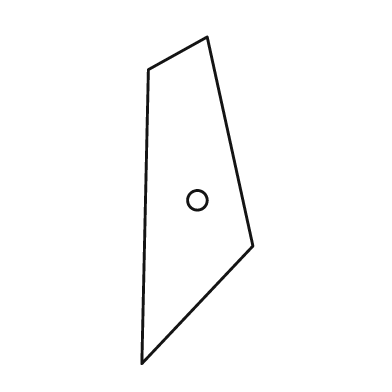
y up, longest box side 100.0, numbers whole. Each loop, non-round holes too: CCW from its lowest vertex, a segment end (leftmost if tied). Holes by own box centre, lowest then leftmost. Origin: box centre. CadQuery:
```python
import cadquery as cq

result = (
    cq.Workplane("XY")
    .moveTo(-17.0, -50.0)
    .lineTo(17.0, -14.0)
    .lineTo(3.0, 50.0)
    .lineTo(-15.0, 40.0)
    .close()
    .moveTo(0.0, 0.0)
    .circle(3.0)
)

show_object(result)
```